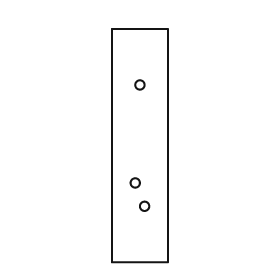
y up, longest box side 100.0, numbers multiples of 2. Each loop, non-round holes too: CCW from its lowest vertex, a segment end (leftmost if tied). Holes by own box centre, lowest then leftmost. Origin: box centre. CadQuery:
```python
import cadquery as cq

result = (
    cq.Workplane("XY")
    .moveTo(-12.0, -50.0)
    .lineTo(12.0, -50.0)
    .lineTo(12.0, 50.0)
    .lineTo(-12.0, 50.0)
    .close()
    .moveTo(2.0, -26.0)
    .circle(2.0)
    .moveTo(-2.0, -16.0)
    .circle(2.0)
    .moveTo(0.0, 26.0)
    .circle(2.0)
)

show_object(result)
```